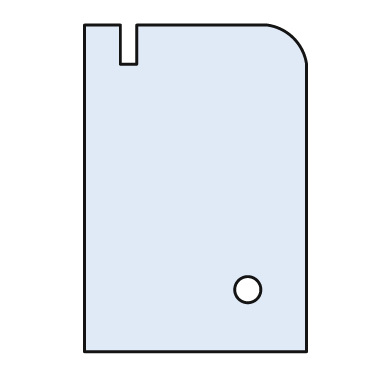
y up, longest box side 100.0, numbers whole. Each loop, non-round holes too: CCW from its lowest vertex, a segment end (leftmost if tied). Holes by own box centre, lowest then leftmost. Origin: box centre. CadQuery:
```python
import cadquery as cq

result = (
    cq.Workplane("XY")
    .moveTo(-34.0, -50.0)
    .lineTo(34.0, -50.0)
    .lineTo(34.0, 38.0)
    .threePointArc((30.0, 46.0), (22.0, 50.0))
    .lineTo(-18.0, 50.0)
    .lineTo(-18.0, 38.0)
    .lineTo(-23.0, 38.0)
    .lineTo(-23.0, 50.0)
    .lineTo(-34.0, 50.0)
    .close()
    .moveTo(16.0, -31.0)
    .circle(4.0)
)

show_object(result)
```